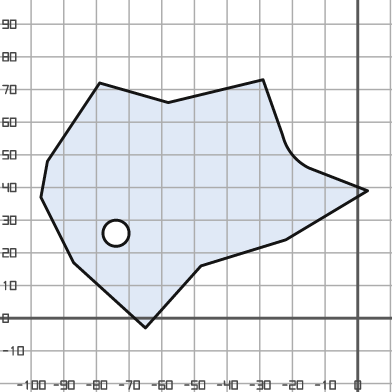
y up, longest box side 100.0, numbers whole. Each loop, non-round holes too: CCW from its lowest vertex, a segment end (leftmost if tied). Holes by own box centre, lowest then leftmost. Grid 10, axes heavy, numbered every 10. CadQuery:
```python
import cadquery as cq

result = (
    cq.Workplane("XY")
    .moveTo(-65.0, -3.0)
    .lineTo(-48.0, 16.0)
    .lineTo(-22.0, 24.0)
    .lineTo(3.0, 39.0)
    .lineTo(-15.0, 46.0)
    .threePointArc((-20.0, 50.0), (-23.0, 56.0))
    .lineTo(-29.0, 73.0)
    .lineTo(-58.0, 66.0)
    .lineTo(-79.0, 72.0)
    .lineTo(-95.0, 48.0)
    .lineTo(-97.0, 37.0)
    .lineTo(-87.0, 17.0)
    .close()
    .moveTo(-74.0, 26.0)
    .circle(4.0)
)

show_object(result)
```